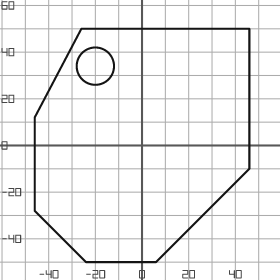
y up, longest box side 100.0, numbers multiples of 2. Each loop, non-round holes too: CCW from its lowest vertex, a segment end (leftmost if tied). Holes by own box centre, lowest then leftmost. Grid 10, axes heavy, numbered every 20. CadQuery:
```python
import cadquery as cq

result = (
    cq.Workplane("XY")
    .moveTo(-24.0, -50.0)
    .lineTo(6.0, -50.0)
    .lineTo(46.0, -10.0)
    .lineTo(46.0, 50.0)
    .lineTo(-26.0, 50.0)
    .lineTo(-46.0, 12.0)
    .lineTo(-46.0, -28.0)
    .close()
    .moveTo(-20.0, 34.0)
    .circle(8.0)
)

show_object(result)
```